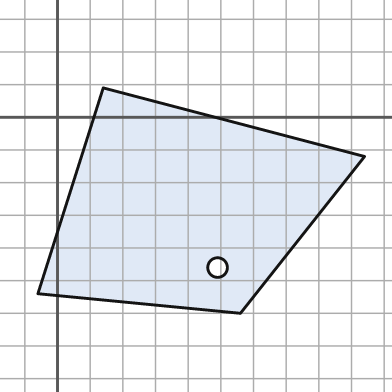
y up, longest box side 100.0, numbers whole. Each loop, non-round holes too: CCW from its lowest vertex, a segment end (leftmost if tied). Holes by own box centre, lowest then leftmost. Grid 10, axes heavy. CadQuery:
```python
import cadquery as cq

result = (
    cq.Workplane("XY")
    .moveTo(56.0, -60.0)
    .lineTo(94.0, -12.0)
    .lineTo(14.0, 9.0)
    .lineTo(-6.0, -54.0)
    .close()
    .moveTo(49.0, -46.0)
    .circle(3.0)
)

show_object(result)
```